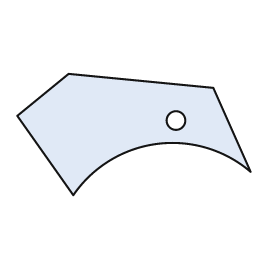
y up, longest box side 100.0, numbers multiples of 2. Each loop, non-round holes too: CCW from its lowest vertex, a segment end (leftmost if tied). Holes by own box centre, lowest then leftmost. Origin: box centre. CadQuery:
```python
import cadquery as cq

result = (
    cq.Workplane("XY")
    .moveTo(-26.0, -26.0)
    .threePointArc((10.0, -4.0), (50.0, -16.0))
    .lineTo(34.0, 20.0)
    .lineTo(-28.0, 26.0)
    .lineTo(-50.0, 8.0)
    .close()
    .moveTo(18.0, 6.0)
    .circle(4.0)
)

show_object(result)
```